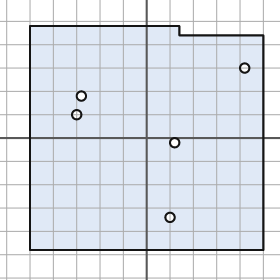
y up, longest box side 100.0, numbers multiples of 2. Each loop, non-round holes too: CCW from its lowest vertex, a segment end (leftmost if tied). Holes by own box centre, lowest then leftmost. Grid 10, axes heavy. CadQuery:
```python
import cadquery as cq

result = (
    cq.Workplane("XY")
    .moveTo(-50.0, -48.0)
    .lineTo(50.0, -48.0)
    .lineTo(50.0, 44.0)
    .lineTo(14.0, 44.0)
    .lineTo(14.0, 48.0)
    .lineTo(-50.0, 48.0)
    .close()
    .moveTo(10.0, -34.0)
    .circle(2.0)
    .moveTo(12.0, -2.0)
    .circle(2.0)
    .moveTo(-30.0, 10.0)
    .circle(2.0)
    .moveTo(-28.0, 18.0)
    .circle(2.0)
    .moveTo(42.0, 30.0)
    .circle(2.0)
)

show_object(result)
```